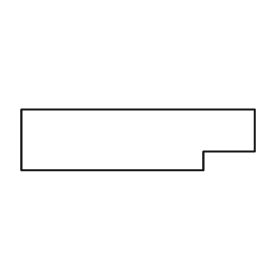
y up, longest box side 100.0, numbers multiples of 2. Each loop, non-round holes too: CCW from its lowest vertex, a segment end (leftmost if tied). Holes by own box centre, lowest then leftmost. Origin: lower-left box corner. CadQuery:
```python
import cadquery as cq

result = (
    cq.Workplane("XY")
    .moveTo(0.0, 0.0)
    .lineTo(78.0, 0.0)
    .lineTo(78.0, 8.0)
    .lineTo(100.0, 8.0)
    .lineTo(100.0, 26.0)
    .lineTo(0.0, 26.0)
    .close()
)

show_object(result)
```